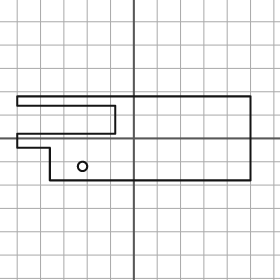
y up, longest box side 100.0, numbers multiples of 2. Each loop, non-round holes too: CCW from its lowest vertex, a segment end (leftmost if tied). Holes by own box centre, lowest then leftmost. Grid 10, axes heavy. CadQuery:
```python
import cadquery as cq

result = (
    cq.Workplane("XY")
    .moveTo(-36.0, -18.0)
    .lineTo(50.0, -18.0)
    .lineTo(50.0, 18.0)
    .lineTo(-50.0, 18.0)
    .lineTo(-50.0, 14.0)
    .lineTo(-8.0, 14.0)
    .lineTo(-8.0, 2.0)
    .lineTo(-50.0, 2.0)
    .lineTo(-50.0, -4.0)
    .lineTo(-36.0, -4.0)
    .close()
    .moveTo(-22.0, -12.0)
    .circle(2.0)
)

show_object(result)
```